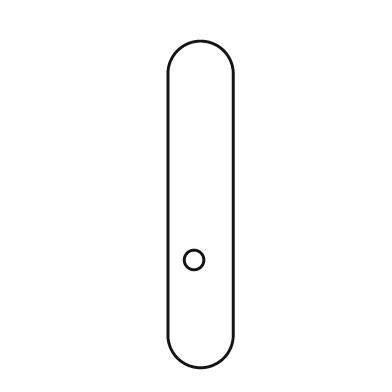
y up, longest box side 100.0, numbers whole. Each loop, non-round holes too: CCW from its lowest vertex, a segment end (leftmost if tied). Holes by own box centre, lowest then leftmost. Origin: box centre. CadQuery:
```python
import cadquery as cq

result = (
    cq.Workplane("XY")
    .moveTo(-10.0, -40.0)
    .threePointArc((0.0, -50.0), (10.0, -40.0))
    .lineTo(10.0, 40.0)
    .threePointArc((0.0, 50.0), (-10.0, 40.0))
    .close()
    .moveTo(-2.0, -17.0)
    .circle(3.0)
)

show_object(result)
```